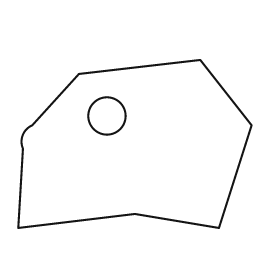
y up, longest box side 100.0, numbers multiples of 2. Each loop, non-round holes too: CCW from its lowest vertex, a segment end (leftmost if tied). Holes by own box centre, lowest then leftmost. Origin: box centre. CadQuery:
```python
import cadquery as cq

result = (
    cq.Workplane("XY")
    .moveTo(-50.0, -36.0)
    .lineTo(0.0, -30.0)
    .lineTo(36.0, -36.0)
    .lineTo(50.0, 8.0)
    .lineTo(28.0, 36.0)
    .lineTo(-24.0, 30.0)
    .lineTo(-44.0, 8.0)
    .threePointArc((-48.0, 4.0), (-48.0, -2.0))
    .close()
    .moveTo(-12.0, 12.0)
    .circle(8.0)
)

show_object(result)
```